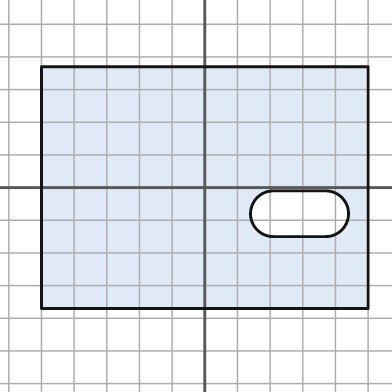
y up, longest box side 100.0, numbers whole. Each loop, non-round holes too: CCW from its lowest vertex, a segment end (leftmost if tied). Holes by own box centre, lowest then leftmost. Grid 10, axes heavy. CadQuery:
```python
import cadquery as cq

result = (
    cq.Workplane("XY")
    .moveTo(-50.0, -37.0)
    .lineTo(50.0, -37.0)
    .lineTo(50.0, 37.0)
    .lineTo(-50.0, 37.0)
    .close()
    .moveTo(21.0, -15.0)
    .lineTo(37.0, -15.0)
    .threePointArc((44.0, -8.0), (37.0, -1.0))
    .lineTo(21.0, -1.0)
    .threePointArc((14.0, -8.0), (21.0, -15.0))
    .close()
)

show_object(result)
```